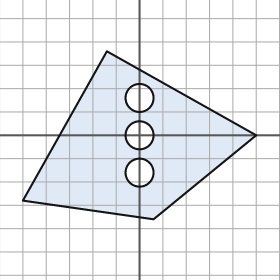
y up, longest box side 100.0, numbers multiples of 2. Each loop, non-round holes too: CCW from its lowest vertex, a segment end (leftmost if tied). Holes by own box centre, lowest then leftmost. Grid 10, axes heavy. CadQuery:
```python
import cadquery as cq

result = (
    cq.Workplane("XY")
    .moveTo(6.0, -36.0)
    .lineTo(50.0, 0.0)
    .lineTo(-14.0, 36.0)
    .lineTo(-50.0, -28.0)
    .close()
    .moveTo(0.0, -16.0)
    .circle(6.0)
    .moveTo(0.0, 0.0)
    .circle(6.0)
    .moveTo(0.0, 16.0)
    .circle(6.0)
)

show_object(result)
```